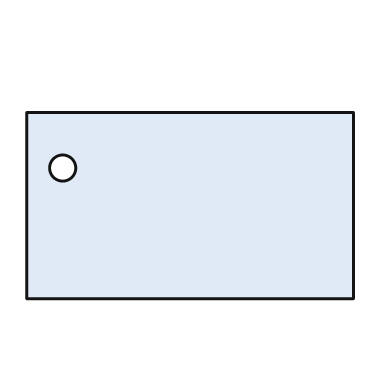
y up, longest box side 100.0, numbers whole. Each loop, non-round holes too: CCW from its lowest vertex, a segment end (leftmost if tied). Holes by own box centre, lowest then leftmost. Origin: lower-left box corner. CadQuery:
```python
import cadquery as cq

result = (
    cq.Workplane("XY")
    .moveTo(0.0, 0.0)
    .lineTo(100.0, 0.0)
    .lineTo(100.0, 57.0)
    .lineTo(0.0, 57.0)
    .close()
    .moveTo(11.0, 40.0)
    .circle(4.0)
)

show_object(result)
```